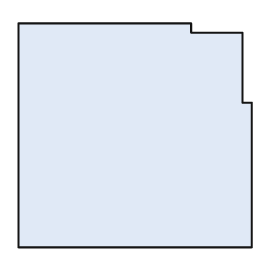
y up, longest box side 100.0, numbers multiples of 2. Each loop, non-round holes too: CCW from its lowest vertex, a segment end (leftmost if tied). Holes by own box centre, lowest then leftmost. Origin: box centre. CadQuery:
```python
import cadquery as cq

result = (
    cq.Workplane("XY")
    .moveTo(-50.0, -48.0)
    .lineTo(50.0, -48.0)
    .lineTo(50.0, 14.0)
    .lineTo(46.0, 14.0)
    .lineTo(46.0, 44.0)
    .lineTo(24.0, 44.0)
    .lineTo(24.0, 48.0)
    .lineTo(-50.0, 48.0)
    .close()
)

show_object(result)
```